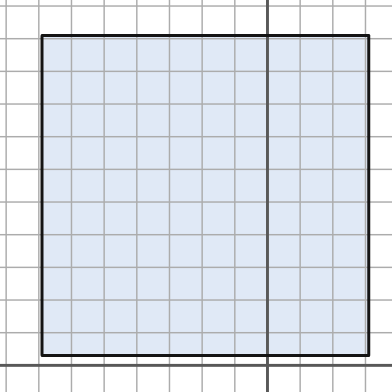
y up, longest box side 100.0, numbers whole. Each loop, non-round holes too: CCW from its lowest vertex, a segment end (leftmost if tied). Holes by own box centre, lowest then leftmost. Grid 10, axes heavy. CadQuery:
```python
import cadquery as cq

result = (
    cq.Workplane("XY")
    .moveTo(-69.0, 3.0)
    .lineTo(31.0, 3.0)
    .lineTo(31.0, 101.0)
    .lineTo(-69.0, 101.0)
    .close()
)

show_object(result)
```